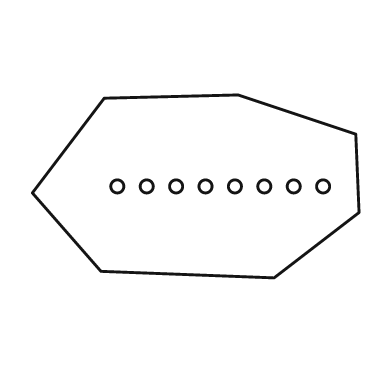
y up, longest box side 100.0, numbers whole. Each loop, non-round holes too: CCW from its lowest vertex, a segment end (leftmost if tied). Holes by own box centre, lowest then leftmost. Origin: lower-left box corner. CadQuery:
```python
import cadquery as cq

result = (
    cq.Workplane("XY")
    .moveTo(74.0, 0.0)
    .lineTo(100.0, 20.0)
    .lineTo(99.0, 44.0)
    .lineTo(63.0, 56.0)
    .lineTo(22.0, 55.0)
    .lineTo(0.0, 26.0)
    .lineTo(21.0, 2.0)
    .close()
    .moveTo(26.0, 28.0)
    .circle(2.0)
    .moveTo(35.0, 28.0)
    .circle(2.0)
    .moveTo(44.0, 28.0)
    .circle(2.0)
    .moveTo(53.0, 28.0)
    .circle(2.0)
    .moveTo(62.0, 28.0)
    .circle(2.0)
    .moveTo(71.0, 28.0)
    .circle(2.0)
    .moveTo(80.0, 28.0)
    .circle(2.0)
    .moveTo(89.0, 28.0)
    .circle(2.0)
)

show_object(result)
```